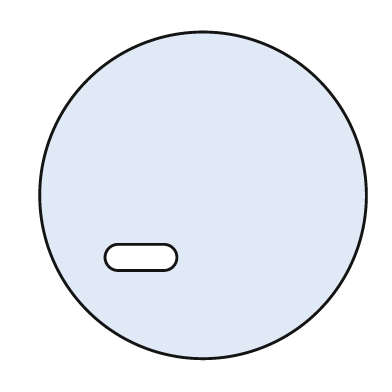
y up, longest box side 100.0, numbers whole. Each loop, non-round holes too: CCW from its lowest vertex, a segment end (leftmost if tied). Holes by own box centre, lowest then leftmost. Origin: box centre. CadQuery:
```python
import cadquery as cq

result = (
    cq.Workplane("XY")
    .moveTo(0.0, 0.0)
    .circle(50.0)
    .moveTo(-26.0, -23.0)
    .lineTo(-12.0, -23.0)
    .threePointArc((-8.0, -19.0), (-12.0, -15.0))
    .lineTo(-26.0, -15.0)
    .threePointArc((-30.0, -19.0), (-26.0, -23.0))
    .close()
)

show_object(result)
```